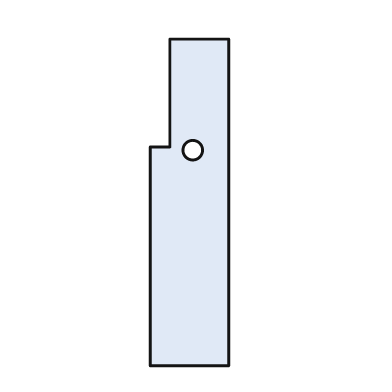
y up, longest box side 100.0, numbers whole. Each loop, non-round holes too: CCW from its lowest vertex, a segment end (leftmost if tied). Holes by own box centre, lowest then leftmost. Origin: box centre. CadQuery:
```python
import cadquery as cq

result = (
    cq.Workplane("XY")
    .moveTo(-12.0, -50.0)
    .lineTo(12.0, -50.0)
    .lineTo(12.0, 50.0)
    .lineTo(-6.0, 50.0)
    .lineTo(-6.0, 17.0)
    .lineTo(-12.0, 17.0)
    .close()
    .moveTo(1.0, 16.0)
    .circle(3.0)
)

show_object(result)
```